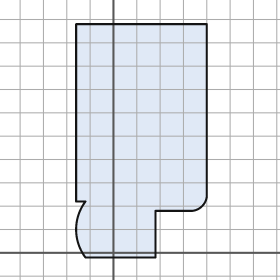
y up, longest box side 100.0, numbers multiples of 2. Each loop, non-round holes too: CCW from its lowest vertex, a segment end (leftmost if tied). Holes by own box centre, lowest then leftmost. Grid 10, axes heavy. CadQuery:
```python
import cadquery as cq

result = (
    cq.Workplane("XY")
    .moveTo(-12.0, -2.0)
    .lineTo(18.0, -2.0)
    .lineTo(18.0, 18.0)
    .lineTo(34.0, 18.0)
    .threePointArc((38.0, 20.0), (40.0, 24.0))
    .lineTo(40.0, 98.0)
    .lineTo(-16.0, 98.0)
    .lineTo(-16.0, 22.0)
    .lineTo(-12.0, 22.0)
    .threePointArc((-16.0, 10.0), (-12.0, -2.0))
    .close()
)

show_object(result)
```